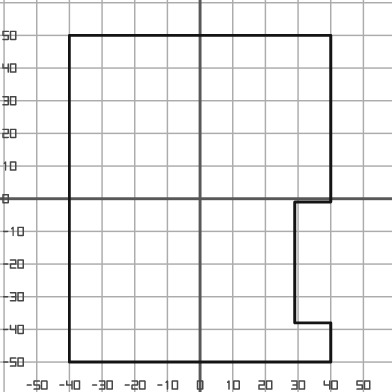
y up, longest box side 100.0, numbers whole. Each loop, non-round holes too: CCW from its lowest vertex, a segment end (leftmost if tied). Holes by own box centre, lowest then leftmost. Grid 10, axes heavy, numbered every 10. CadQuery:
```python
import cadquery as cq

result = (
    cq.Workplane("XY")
    .moveTo(-40.0, -50.0)
    .lineTo(40.0, -50.0)
    .lineTo(40.0, -38.0)
    .lineTo(29.0, -38.0)
    .lineTo(29.0, -1.0)
    .lineTo(40.0, -1.0)
    .lineTo(40.0, 50.0)
    .lineTo(-40.0, 50.0)
    .close()
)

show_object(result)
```